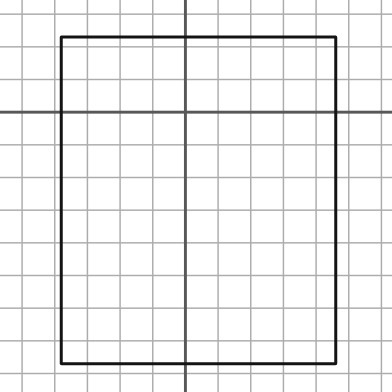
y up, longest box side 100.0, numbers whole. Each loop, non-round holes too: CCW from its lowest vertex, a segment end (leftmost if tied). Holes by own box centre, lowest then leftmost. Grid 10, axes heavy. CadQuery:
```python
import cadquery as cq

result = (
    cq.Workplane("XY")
    .moveTo(-38.0, -77.0)
    .lineTo(46.0, -77.0)
    .lineTo(46.0, 23.0)
    .lineTo(-38.0, 23.0)
    .close()
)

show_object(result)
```